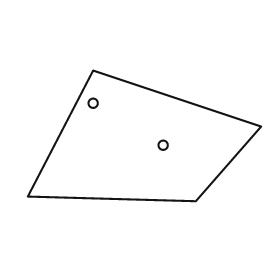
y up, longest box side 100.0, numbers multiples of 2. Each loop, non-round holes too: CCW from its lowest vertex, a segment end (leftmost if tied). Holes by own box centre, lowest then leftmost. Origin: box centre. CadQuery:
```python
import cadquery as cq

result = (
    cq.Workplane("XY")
    .moveTo(22.0, -28.0)
    .lineTo(50.0, 4.0)
    .lineTo(-22.0, 28.0)
    .lineTo(-50.0, -26.0)
    .close()
    .moveTo(8.0, -4.0)
    .circle(2.0)
    .moveTo(-22.0, 14.0)
    .circle(2.0)
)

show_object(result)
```